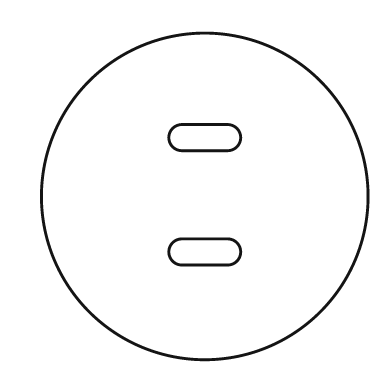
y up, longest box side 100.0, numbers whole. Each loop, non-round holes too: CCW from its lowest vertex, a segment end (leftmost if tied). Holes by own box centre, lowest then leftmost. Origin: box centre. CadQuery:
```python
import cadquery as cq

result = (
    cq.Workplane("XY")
    .moveTo(0.0, 0.0)
    .circle(50.0)
    .moveTo(-7.0, -21.0)
    .lineTo(7.0, -21.0)
    .threePointArc((11.0, -17.0), (7.0, -13.0))
    .lineTo(-7.0, -13.0)
    .threePointArc((-11.0, -17.0), (-7.0, -21.0))
    .close()
    .moveTo(-7.0, 14.0)
    .lineTo(7.0, 14.0)
    .threePointArc((11.0, 18.0), (7.0, 22.0))
    .lineTo(-7.0, 22.0)
    .threePointArc((-11.0, 18.0), (-7.0, 14.0))
    .close()
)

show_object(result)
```